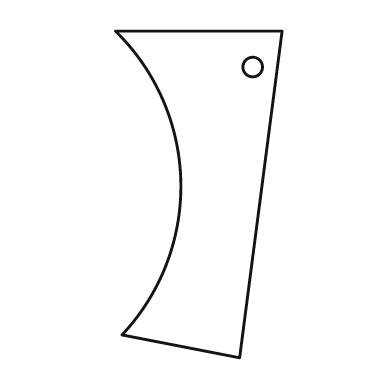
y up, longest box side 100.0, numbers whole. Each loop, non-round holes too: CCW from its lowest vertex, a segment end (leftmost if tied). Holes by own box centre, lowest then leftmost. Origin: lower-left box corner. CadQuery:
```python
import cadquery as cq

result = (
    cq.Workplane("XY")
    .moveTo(38.0, 0.0)
    .lineTo(51.0, 100.0)
    .lineTo(0.0, 100.0)
    .threePointArc((20.0, 54.0), (2.0, 7.0))
    .close()
    .moveTo(42.0, 89.0)
    .circle(3.0)
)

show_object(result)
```